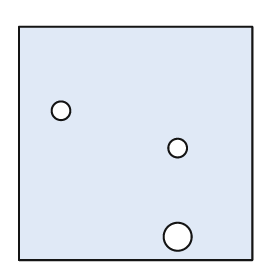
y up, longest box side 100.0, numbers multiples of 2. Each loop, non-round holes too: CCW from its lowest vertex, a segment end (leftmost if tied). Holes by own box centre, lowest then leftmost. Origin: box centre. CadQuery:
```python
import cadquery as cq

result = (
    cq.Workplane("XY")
    .moveTo(-50.0, -50.0)
    .lineTo(50.0, -50.0)
    .lineTo(50.0, 50.0)
    .lineTo(-50.0, 50.0)
    .close()
    .moveTo(18.0, -40.0)
    .circle(6.0)
    .moveTo(18.0, -2.0)
    .circle(4.0)
    .moveTo(-32.0, 14.0)
    .circle(4.0)
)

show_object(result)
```